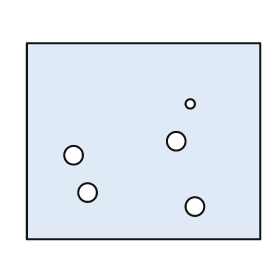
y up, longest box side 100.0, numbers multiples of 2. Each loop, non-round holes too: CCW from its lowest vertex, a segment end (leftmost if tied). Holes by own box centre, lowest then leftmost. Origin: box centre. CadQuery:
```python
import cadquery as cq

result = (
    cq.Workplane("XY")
    .moveTo(-50.0, -42.0)
    .lineTo(50.0, -42.0)
    .lineTo(50.0, 42.0)
    .lineTo(-50.0, 42.0)
    .close()
    .moveTo(22.0, -28.0)
    .circle(4.0)
    .moveTo(-24.0, -22.0)
    .circle(4.0)
    .moveTo(-30.0, -6.0)
    .circle(4.0)
    .moveTo(14.0, 0.0)
    .circle(4.0)
    .moveTo(20.0, 16.0)
    .circle(2.0)
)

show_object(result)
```